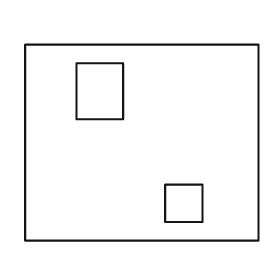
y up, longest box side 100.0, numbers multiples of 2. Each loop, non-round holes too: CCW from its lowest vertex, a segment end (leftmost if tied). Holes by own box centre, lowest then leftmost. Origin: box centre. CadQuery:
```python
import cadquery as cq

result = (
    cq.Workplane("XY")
    .moveTo(-50.0, -42.0)
    .lineTo(50.0, -42.0)
    .lineTo(50.0, 42.0)
    .lineTo(-50.0, 42.0)
    .close()
    .moveTo(10.0, -34.0)
    .lineTo(26.0, -34.0)
    .lineTo(26.0, -18.0)
    .lineTo(10.0, -18.0)
    .close()
    .moveTo(-28.0, 10.0)
    .lineTo(-8.0, 10.0)
    .lineTo(-8.0, 34.0)
    .lineTo(-28.0, 34.0)
    .close()
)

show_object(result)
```